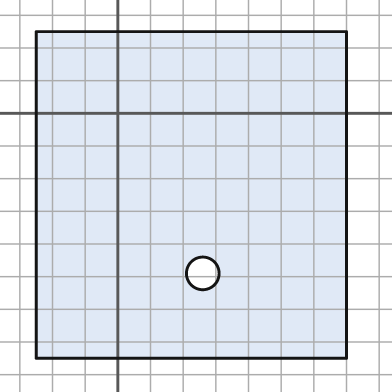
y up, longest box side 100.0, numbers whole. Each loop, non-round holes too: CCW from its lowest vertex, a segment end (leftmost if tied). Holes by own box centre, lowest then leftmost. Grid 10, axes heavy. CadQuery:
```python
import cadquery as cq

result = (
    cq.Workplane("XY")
    .moveTo(-25.0, -75.0)
    .lineTo(70.0, -75.0)
    .lineTo(70.0, 25.0)
    .lineTo(-25.0, 25.0)
    .close()
    .moveTo(26.0, -49.0)
    .circle(5.0)
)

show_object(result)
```